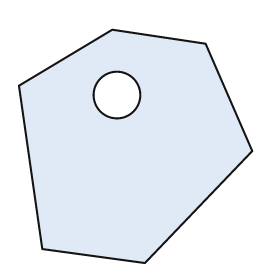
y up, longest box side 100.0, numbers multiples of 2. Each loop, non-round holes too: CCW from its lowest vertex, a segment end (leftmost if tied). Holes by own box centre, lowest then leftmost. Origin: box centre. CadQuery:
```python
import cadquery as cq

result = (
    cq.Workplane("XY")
    .moveTo(4.0, -50.0)
    .lineTo(50.0, -2.0)
    .lineTo(30.0, 44.0)
    .lineTo(-10.0, 50.0)
    .lineTo(-50.0, 26.0)
    .lineTo(-40.0, -44.0)
    .close()
    .moveTo(-8.0, 22.0)
    .circle(10.0)
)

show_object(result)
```